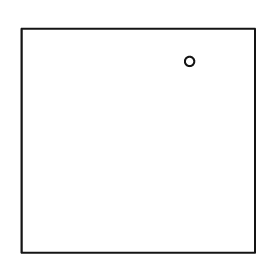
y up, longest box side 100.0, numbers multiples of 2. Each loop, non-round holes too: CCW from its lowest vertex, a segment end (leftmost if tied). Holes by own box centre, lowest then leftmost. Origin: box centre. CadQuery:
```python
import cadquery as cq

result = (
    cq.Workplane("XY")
    .moveTo(-50.0, -48.0)
    .lineTo(50.0, -48.0)
    .lineTo(50.0, 48.0)
    .lineTo(-50.0, 48.0)
    .close()
    .moveTo(22.0, 34.0)
    .circle(2.0)
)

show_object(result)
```